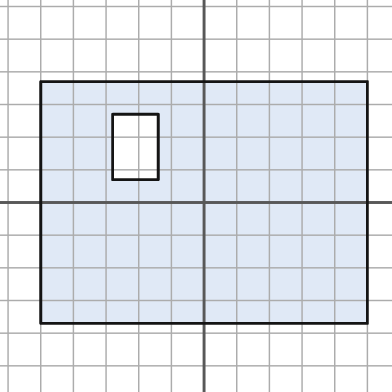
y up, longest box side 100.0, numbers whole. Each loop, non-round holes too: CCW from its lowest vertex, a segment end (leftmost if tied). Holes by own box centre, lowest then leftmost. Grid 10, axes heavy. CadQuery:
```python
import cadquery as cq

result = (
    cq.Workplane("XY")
    .moveTo(-50.0, -37.0)
    .lineTo(50.0, -37.0)
    .lineTo(50.0, 37.0)
    .lineTo(-50.0, 37.0)
    .close()
    .moveTo(-28.0, 7.0)
    .lineTo(-14.0, 7.0)
    .lineTo(-14.0, 27.0)
    .lineTo(-28.0, 27.0)
    .close()
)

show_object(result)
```